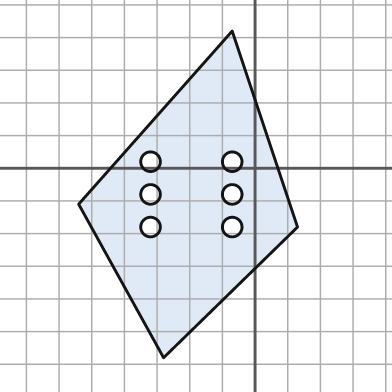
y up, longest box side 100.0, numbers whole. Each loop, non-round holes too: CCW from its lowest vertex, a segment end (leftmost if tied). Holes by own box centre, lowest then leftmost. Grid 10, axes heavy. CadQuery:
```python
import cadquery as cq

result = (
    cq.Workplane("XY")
    .moveTo(-28.0, -58.0)
    .lineTo(13.0, -18.0)
    .lineTo(-7.0, 42.0)
    .lineTo(-54.0, -11.0)
    .close()
    .moveTo(-32.0, -18.0)
    .circle(3.0)
    .moveTo(-7.0, -18.0)
    .circle(3.0)
    .moveTo(-32.0, -8.0)
    .circle(3.0)
    .moveTo(-7.0, -8.0)
    .circle(3.0)
    .moveTo(-32.0, 2.0)
    .circle(3.0)
    .moveTo(-7.0, 2.0)
    .circle(3.0)
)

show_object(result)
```